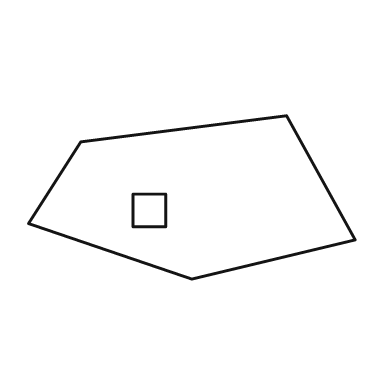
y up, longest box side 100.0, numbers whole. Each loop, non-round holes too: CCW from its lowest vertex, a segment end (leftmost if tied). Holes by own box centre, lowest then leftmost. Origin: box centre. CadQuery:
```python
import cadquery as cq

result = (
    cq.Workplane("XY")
    .moveTo(0.0, -25.0)
    .lineTo(50.0, -13.0)
    .lineTo(29.0, 25.0)
    .lineTo(-34.0, 17.0)
    .lineTo(-50.0, -8.0)
    .close()
    .moveTo(-18.0, -9.0)
    .lineTo(-8.0, -9.0)
    .lineTo(-8.0, 1.0)
    .lineTo(-18.0, 1.0)
    .close()
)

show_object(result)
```